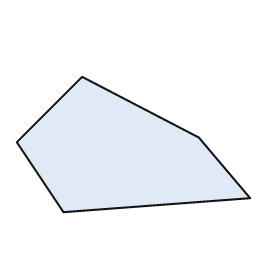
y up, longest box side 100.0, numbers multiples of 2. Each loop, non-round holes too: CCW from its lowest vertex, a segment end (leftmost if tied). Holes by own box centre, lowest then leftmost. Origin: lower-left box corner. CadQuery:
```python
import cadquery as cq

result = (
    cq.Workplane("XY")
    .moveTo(20.0, 0.0)
    .lineTo(100.0, 6.0)
    .lineTo(78.0, 32.0)
    .lineTo(28.0, 58.0)
    .lineTo(0.0, 30.0)
    .close()
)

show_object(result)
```